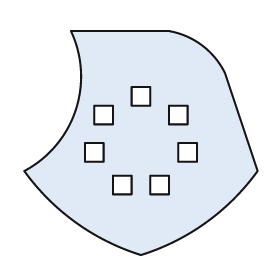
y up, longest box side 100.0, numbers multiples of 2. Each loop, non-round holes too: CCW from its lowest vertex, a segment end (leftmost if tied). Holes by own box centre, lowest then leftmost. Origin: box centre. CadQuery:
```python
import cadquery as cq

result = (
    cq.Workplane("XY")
    .moveTo(0.0, -48.0)
    .threePointArc((28.0, -34.0), (50.0, -12.0))
    .lineTo(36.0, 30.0)
    .threePointArc((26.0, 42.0), (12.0, 48.0))
    .lineTo(-30.0, 48.0)
    .threePointArc((-28.0, 14.0), (-50.0, -12.0))
    .threePointArc((-28.0, -34.0), (0.0, -48.0))
    .close()
    .moveTo(-12.0, -22.0)
    .lineTo(-4.0, -22.0)
    .lineTo(-4.0, -14.0)
    .lineTo(-12.0, -14.0)
    .close()
    .moveTo(4.0, -22.0)
    .lineTo(12.0, -22.0)
    .lineTo(12.0, -14.0)
    .lineTo(4.0, -14.0)
    .close()
    .moveTo(-24.0, -8.0)
    .lineTo(-16.0, -8.0)
    .lineTo(-16.0, 0.0)
    .lineTo(-24.0, 0.0)
    .close()
    .moveTo(16.0, -8.0)
    .lineTo(24.0, -8.0)
    .lineTo(24.0, 0.0)
    .lineTo(16.0, 0.0)
    .close()
    .moveTo(-20.0, 8.0)
    .lineTo(-12.0, 8.0)
    .lineTo(-12.0, 16.0)
    .lineTo(-20.0, 16.0)
    .close()
    .moveTo(12.0, 8.0)
    .lineTo(20.0, 8.0)
    .lineTo(20.0, 16.0)
    .lineTo(12.0, 16.0)
    .close()
    .moveTo(-4.0, 16.0)
    .lineTo(4.0, 16.0)
    .lineTo(4.0, 24.0)
    .lineTo(-4.0, 24.0)
    .close()
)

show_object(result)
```